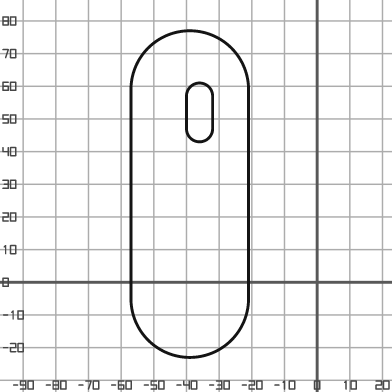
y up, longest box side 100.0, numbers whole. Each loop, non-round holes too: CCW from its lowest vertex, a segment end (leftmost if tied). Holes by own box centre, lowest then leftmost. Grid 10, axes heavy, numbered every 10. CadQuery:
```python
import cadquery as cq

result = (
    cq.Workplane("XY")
    .moveTo(-57.0, -5.0)
    .threePointArc((-39.0, -23.0), (-21.0, -5.0))
    .lineTo(-21.0, 59.0)
    .threePointArc((-39.0, 77.0), (-57.0, 59.0))
    .close()
    .moveTo(-40.0, 47.0)
    .threePointArc((-36.0, 43.0), (-32.0, 47.0))
    .lineTo(-32.0, 57.0)
    .threePointArc((-36.0, 61.0), (-40.0, 57.0))
    .close()
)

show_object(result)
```